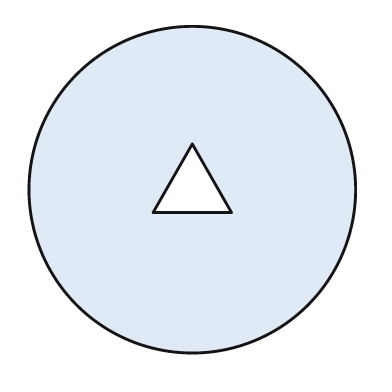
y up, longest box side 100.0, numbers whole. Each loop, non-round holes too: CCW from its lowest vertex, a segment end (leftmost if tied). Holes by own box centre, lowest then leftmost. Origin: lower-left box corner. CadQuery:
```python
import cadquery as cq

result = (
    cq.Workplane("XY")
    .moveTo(50.0, 50.0)
    .circle(50.0)
    .moveTo(38.0, 43.0)
    .lineTo(62.0, 43.0)
    .lineTo(50.0, 64.0)
    .close()
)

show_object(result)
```